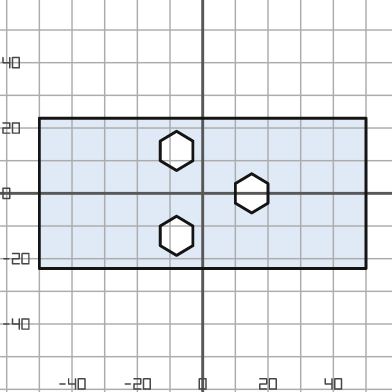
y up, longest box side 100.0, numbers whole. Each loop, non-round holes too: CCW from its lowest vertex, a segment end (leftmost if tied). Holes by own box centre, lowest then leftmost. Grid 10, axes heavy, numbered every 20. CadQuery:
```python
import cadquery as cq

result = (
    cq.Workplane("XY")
    .moveTo(-50.0, -23.0)
    .lineTo(50.0, -23.0)
    .lineTo(50.0, 23.0)
    .lineTo(-50.0, 23.0)
    .close()
    .moveTo(-8.0, -19.0)
    .lineTo(-3.0, -16.0)
    .lineTo(-3.0, -10.0)
    .lineTo(-8.0, -7.0)
    .lineTo(-13.0, -10.0)
    .lineTo(-13.0, -16.0)
    .close()
    .moveTo(15.0, -6.0)
    .lineTo(20.0, -3.0)
    .lineTo(20.0, 3.0)
    .lineTo(15.0, 6.0)
    .lineTo(10.0, 3.0)
    .lineTo(10.0, -3.0)
    .close()
    .moveTo(-8.0, 7.0)
    .lineTo(-3.0, 10.0)
    .lineTo(-3.0, 16.0)
    .lineTo(-8.0, 19.0)
    .lineTo(-13.0, 16.0)
    .lineTo(-13.0, 10.0)
    .close()
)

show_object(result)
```